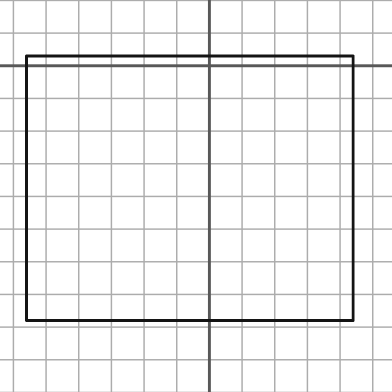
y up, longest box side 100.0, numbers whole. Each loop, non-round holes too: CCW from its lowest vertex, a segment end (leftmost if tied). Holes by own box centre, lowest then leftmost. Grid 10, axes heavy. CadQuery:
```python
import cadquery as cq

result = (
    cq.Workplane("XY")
    .moveTo(-56.0, -78.0)
    .lineTo(44.0, -78.0)
    .lineTo(44.0, 3.0)
    .lineTo(-56.0, 3.0)
    .close()
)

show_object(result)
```